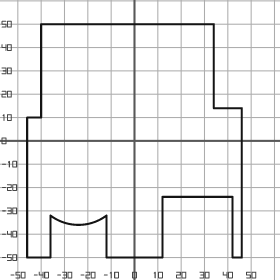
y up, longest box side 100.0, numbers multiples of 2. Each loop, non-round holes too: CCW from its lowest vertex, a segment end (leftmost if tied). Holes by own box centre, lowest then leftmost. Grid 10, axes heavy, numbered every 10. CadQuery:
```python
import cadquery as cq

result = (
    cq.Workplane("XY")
    .moveTo(-46.0, -50.0)
    .lineTo(-36.0, -50.0)
    .lineTo(-36.0, -32.0)
    .threePointArc((-24.0, -36.0), (-12.0, -32.0))
    .lineTo(-12.0, -50.0)
    .lineTo(12.0, -50.0)
    .lineTo(12.0, -24.0)
    .lineTo(42.0, -24.0)
    .lineTo(42.0, -50.0)
    .lineTo(46.0, -50.0)
    .lineTo(46.0, 14.0)
    .lineTo(34.0, 14.0)
    .lineTo(34.0, 50.0)
    .lineTo(-40.0, 50.0)
    .lineTo(-40.0, 10.0)
    .lineTo(-46.0, 10.0)
    .close()
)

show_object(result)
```